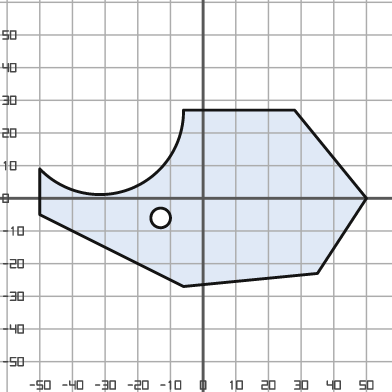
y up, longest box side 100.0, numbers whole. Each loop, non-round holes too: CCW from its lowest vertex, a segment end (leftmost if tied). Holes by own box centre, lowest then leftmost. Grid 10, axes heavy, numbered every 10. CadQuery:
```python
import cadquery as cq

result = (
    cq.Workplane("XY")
    .moveTo(-6.0, -27.0)
    .lineTo(35.0, -23.0)
    .lineTo(50.0, 0.0)
    .lineTo(28.0, 27.0)
    .lineTo(-6.0, 27.0)
    .threePointArc((-22.0, 3.0), (-50.0, 9.0))
    .lineTo(-50.0, -5.0)
    .close()
    .moveTo(-13.0, -6.0)
    .circle(3.0)
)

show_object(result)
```